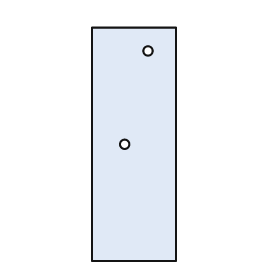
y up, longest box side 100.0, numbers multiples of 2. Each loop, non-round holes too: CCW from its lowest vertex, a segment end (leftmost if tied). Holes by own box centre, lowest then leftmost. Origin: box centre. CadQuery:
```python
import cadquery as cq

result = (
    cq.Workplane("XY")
    .moveTo(-18.0, -50.0)
    .lineTo(18.0, -50.0)
    .lineTo(18.0, 50.0)
    .lineTo(-18.0, 50.0)
    .close()
    .moveTo(-4.0, 0.0)
    .circle(2.0)
    .moveTo(6.0, 40.0)
    .circle(2.0)
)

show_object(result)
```